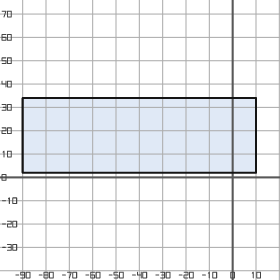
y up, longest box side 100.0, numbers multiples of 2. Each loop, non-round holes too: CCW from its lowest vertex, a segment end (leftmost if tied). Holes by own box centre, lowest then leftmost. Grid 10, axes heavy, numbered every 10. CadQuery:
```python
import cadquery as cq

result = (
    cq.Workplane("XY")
    .moveTo(-90.0, 2.0)
    .lineTo(10.0, 2.0)
    .lineTo(10.0, 34.0)
    .lineTo(-90.0, 34.0)
    .close()
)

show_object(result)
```